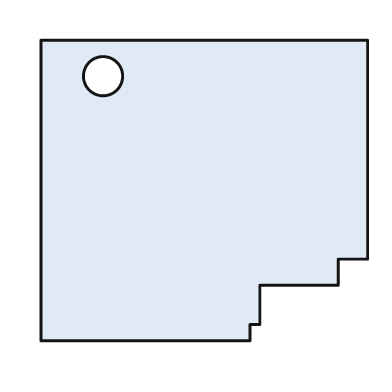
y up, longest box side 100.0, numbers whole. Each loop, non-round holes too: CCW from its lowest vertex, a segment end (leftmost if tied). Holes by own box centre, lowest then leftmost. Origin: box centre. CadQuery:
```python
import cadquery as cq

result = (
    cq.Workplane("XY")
    .moveTo(-50.0, -46.0)
    .lineTo(14.0, -46.0)
    .lineTo(14.0, -41.0)
    .lineTo(17.0, -41.0)
    .lineTo(17.0, -29.0)
    .lineTo(41.0, -29.0)
    .lineTo(41.0, -21.0)
    .lineTo(50.0, -21.0)
    .lineTo(50.0, 46.0)
    .lineTo(-50.0, 46.0)
    .close()
    .moveTo(-31.0, 35.0)
    .circle(6.0)
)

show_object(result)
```